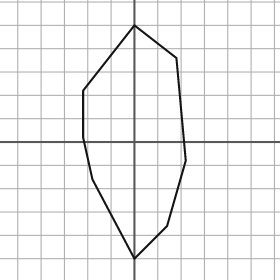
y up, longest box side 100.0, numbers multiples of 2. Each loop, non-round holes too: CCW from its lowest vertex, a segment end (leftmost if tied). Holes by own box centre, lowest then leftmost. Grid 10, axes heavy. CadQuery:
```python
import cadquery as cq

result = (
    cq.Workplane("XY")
    .moveTo(0.0, -50.0)
    .lineTo(14.0, -36.0)
    .lineTo(22.0, -8.0)
    .lineTo(18.0, 36.0)
    .lineTo(0.0, 50.0)
    .lineTo(-22.0, 22.0)
    .lineTo(-22.0, 2.0)
    .lineTo(-18.0, -16.0)
    .close()
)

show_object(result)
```